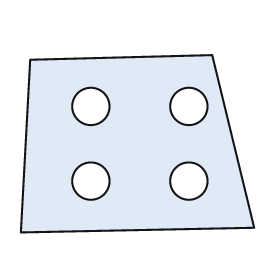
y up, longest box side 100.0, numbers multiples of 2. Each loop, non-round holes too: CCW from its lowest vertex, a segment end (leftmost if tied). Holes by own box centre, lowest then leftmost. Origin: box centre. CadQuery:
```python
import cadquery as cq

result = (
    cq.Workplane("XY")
    .moveTo(-50.0, -38.0)
    .lineTo(50.0, -36.0)
    .lineTo(32.0, 38.0)
    .lineTo(-46.0, 36.0)
    .close()
    .moveTo(-20.0, -16.0)
    .circle(8.0)
    .moveTo(22.0, -16.0)
    .circle(8.0)
    .moveTo(-20.0, 16.0)
    .circle(8.0)
    .moveTo(22.0, 16.0)
    .circle(8.0)
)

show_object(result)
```